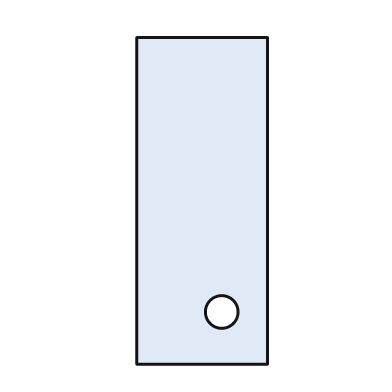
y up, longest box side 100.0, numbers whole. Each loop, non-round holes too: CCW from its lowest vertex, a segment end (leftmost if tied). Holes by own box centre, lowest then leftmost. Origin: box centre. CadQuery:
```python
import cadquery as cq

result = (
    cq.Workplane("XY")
    .moveTo(-20.0, -50.0)
    .lineTo(20.0, -50.0)
    .lineTo(20.0, 50.0)
    .lineTo(-20.0, 50.0)
    .close()
    .moveTo(6.0, -34.0)
    .circle(5.0)
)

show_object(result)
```